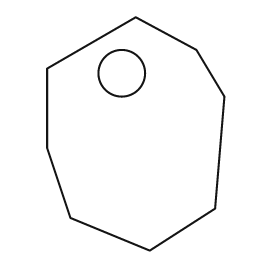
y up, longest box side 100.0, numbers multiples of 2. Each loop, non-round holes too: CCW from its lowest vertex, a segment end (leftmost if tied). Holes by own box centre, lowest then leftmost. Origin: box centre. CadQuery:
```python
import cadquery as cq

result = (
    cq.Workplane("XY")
    .moveTo(6.0, -50.0)
    .lineTo(34.0, -32.0)
    .lineTo(38.0, 16.0)
    .lineTo(26.0, 36.0)
    .lineTo(0.0, 50.0)
    .lineTo(-38.0, 28.0)
    .lineTo(-38.0, -6.0)
    .lineTo(-28.0, -36.0)
    .close()
    .moveTo(-6.0, 26.0)
    .circle(10.0)
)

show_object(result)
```